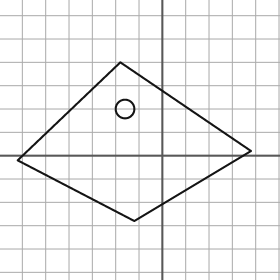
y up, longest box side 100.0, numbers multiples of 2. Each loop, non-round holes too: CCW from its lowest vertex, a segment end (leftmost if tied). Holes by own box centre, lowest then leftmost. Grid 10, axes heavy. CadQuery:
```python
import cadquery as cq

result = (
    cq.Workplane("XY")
    .moveTo(-12.0, -28.0)
    .lineTo(38.0, 2.0)
    .lineTo(-18.0, 40.0)
    .lineTo(-62.0, -2.0)
    .close()
    .moveTo(-16.0, 20.0)
    .circle(4.0)
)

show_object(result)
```